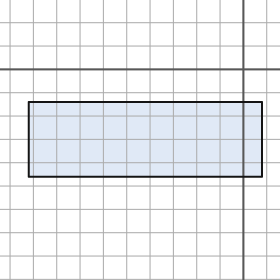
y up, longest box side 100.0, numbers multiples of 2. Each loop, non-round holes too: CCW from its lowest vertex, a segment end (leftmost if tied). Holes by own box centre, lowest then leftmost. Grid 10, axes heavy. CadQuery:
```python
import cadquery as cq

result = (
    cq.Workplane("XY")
    .moveTo(-92.0, -46.0)
    .lineTo(8.0, -46.0)
    .lineTo(8.0, -14.0)
    .lineTo(-92.0, -14.0)
    .close()
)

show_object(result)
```